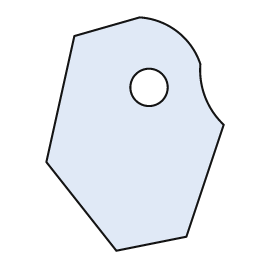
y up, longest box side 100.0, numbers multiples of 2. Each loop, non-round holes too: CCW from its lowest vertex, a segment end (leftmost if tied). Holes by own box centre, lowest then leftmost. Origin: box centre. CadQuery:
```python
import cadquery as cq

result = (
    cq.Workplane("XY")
    .moveTo(-8.0, -50.0)
    .lineTo(22.0, -44.0)
    .lineTo(38.0, 4.0)
    .threePointArc((30.0, 16.0), (28.0, 30.0))
    .threePointArc((18.0, 44.0), (2.0, 50.0))
    .lineTo(-26.0, 42.0)
    .lineTo(-38.0, -12.0)
    .close()
    .moveTo(6.0, 20.0)
    .circle(8.0)
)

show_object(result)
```